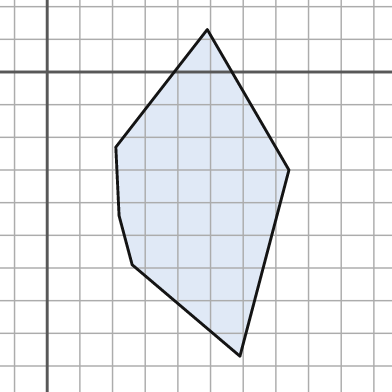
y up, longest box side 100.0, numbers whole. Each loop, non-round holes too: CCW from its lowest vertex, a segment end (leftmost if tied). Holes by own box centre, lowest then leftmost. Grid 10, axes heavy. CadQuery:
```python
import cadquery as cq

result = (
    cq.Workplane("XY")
    .moveTo(59.0, -87.0)
    .lineTo(74.0, -30.0)
    .lineTo(49.0, 13.0)
    .lineTo(21.0, -23.0)
    .lineTo(22.0, -44.0)
    .lineTo(26.0, -59.0)
    .close()
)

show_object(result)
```